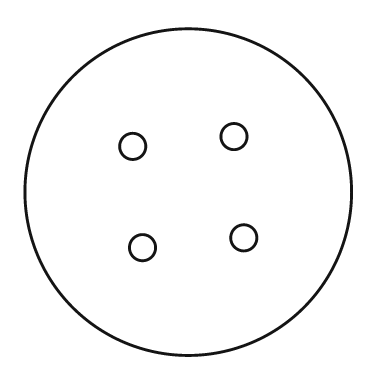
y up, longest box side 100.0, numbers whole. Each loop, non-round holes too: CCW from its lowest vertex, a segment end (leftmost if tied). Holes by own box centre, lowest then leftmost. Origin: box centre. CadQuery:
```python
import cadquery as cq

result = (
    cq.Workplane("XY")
    .moveTo(0.0, 0.0)
    .circle(50.0)
    .moveTo(-14.0, -17.0)
    .circle(4.0)
    .moveTo(17.0, -14.0)
    .circle(4.0)
    .moveTo(-17.0, 14.0)
    .circle(4.0)
    .moveTo(14.0, 17.0)
    .circle(4.0)
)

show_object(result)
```